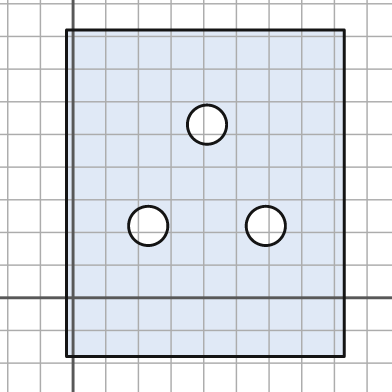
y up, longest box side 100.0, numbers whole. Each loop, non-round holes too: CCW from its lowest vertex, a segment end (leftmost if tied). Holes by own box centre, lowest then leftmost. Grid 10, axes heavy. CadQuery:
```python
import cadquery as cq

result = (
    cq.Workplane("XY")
    .moveTo(-2.0, -18.0)
    .lineTo(83.0, -18.0)
    .lineTo(83.0, 82.0)
    .lineTo(-2.0, 82.0)
    .close()
    .moveTo(23.0, 22.0)
    .circle(6.0)
    .moveTo(59.0, 22.0)
    .circle(6.0)
    .moveTo(41.0, 53.0)
    .circle(6.0)
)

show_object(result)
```